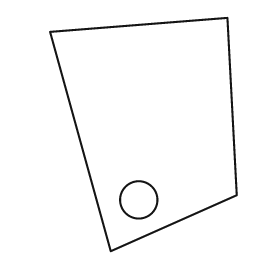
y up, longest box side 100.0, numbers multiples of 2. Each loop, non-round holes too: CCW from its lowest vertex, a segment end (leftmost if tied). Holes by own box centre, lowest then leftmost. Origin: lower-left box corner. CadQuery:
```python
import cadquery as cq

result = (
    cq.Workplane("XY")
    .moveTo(26.0, 0.0)
    .lineTo(80.0, 24.0)
    .lineTo(76.0, 100.0)
    .lineTo(0.0, 94.0)
    .close()
    .moveTo(38.0, 22.0)
    .circle(8.0)
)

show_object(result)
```